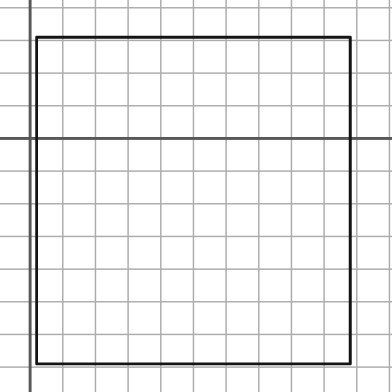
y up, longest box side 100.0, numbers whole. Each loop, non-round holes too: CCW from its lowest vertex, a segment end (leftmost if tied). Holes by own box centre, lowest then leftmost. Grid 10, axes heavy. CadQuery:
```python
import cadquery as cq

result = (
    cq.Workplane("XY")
    .moveTo(2.0, -69.0)
    .lineTo(98.0, -69.0)
    .lineTo(98.0, 31.0)
    .lineTo(2.0, 31.0)
    .close()
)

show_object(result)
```